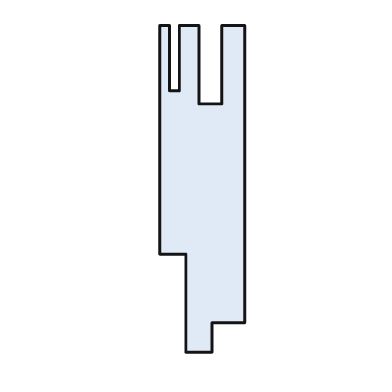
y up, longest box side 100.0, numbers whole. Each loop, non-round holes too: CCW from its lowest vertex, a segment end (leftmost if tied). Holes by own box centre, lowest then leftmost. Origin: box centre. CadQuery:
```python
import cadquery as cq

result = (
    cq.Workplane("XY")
    .moveTo(-5.0, -50.0)
    .lineTo(3.0, -50.0)
    .lineTo(3.0, -41.0)
    .lineTo(13.0, -41.0)
    .lineTo(13.0, 50.0)
    .lineTo(6.0, 50.0)
    .lineTo(6.0, 26.0)
    .lineTo(-1.0, 26.0)
    .lineTo(-1.0, 50.0)
    .lineTo(-7.0, 50.0)
    .lineTo(-7.0, 30.0)
    .lineTo(-10.0, 30.0)
    .lineTo(-10.0, 50.0)
    .lineTo(-13.0, 50.0)
    .lineTo(-13.0, -20.0)
    .lineTo(-5.0, -20.0)
    .close()
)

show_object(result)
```